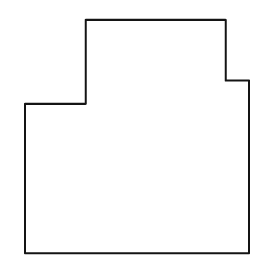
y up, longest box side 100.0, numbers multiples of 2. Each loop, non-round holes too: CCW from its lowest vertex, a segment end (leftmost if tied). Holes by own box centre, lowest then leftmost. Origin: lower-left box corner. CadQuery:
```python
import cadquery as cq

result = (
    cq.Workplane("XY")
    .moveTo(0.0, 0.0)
    .lineTo(96.0, 0.0)
    .lineTo(96.0, 74.0)
    .lineTo(86.0, 74.0)
    .lineTo(86.0, 100.0)
    .lineTo(26.0, 100.0)
    .lineTo(26.0, 64.0)
    .lineTo(0.0, 64.0)
    .close()
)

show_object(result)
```